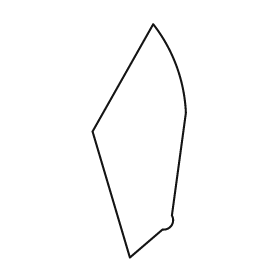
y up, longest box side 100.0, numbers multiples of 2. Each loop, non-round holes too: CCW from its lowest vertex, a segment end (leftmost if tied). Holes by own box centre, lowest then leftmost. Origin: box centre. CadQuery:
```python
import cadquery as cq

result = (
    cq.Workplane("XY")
    .moveTo(-4.0, -50.0)
    .lineTo(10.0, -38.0)
    .threePointArc((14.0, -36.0), (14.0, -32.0))
    .lineTo(20.0, 12.0)
    .threePointArc((16.0, 32.0), (6.0, 50.0))
    .lineTo(-20.0, 4.0)
    .close()
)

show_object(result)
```